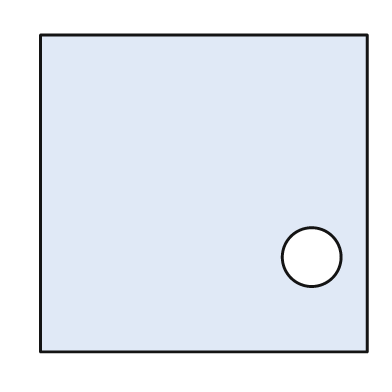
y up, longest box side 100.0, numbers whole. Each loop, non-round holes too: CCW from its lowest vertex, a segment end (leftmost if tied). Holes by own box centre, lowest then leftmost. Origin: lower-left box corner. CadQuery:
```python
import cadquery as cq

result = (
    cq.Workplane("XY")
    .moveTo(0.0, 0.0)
    .lineTo(100.0, 0.0)
    .lineTo(100.0, 97.0)
    .lineTo(0.0, 97.0)
    .close()
    .moveTo(83.0, 29.0)
    .circle(9.0)
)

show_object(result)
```